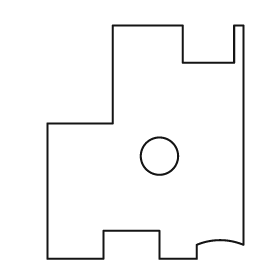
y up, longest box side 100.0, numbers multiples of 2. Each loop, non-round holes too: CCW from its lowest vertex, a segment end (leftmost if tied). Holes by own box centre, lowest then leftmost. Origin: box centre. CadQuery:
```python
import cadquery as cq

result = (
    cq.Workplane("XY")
    .moveTo(-42.0, -50.0)
    .lineTo(-18.0, -50.0)
    .lineTo(-18.0, -38.0)
    .lineTo(6.0, -38.0)
    .lineTo(6.0, -50.0)
    .lineTo(22.0, -50.0)
    .lineTo(22.0, -44.0)
    .threePointArc((32.0, -42.0), (42.0, -44.0))
    .lineTo(42.0, 50.0)
    .lineTo(38.0, 50.0)
    .lineTo(38.0, 34.0)
    .lineTo(16.0, 34.0)
    .lineTo(16.0, 50.0)
    .lineTo(-14.0, 50.0)
    .lineTo(-14.0, 8.0)
    .lineTo(-42.0, 8.0)
    .close()
    .moveTo(6.0, -6.0)
    .circle(8.0)
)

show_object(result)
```